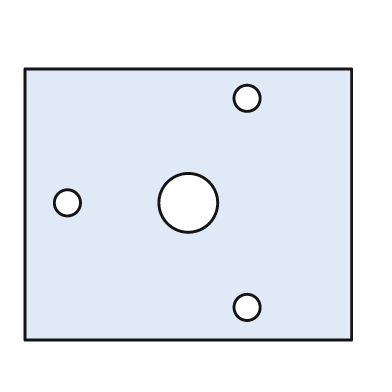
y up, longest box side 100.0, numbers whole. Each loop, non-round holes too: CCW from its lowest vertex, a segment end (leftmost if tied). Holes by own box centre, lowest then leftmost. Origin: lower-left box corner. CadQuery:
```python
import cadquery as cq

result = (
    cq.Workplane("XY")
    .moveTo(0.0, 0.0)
    .lineTo(100.0, 0.0)
    .lineTo(100.0, 83.0)
    .lineTo(0.0, 83.0)
    .close()
    .moveTo(68.0, 10.0)
    .circle(4.0)
    .moveTo(13.0, 42.0)
    .circle(4.0)
    .moveTo(50.0, 42.0)
    .circle(9.0)
    .moveTo(68.0, 74.0)
    .circle(4.0)
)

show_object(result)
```